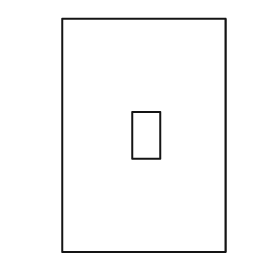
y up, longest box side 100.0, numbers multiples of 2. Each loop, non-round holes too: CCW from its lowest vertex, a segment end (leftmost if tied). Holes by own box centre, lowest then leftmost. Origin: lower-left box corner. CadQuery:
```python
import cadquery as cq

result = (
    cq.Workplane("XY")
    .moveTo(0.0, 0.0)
    .lineTo(70.0, 0.0)
    .lineTo(70.0, 100.0)
    .lineTo(0.0, 100.0)
    .close()
    .moveTo(30.0, 40.0)
    .lineTo(42.0, 40.0)
    .lineTo(42.0, 60.0)
    .lineTo(30.0, 60.0)
    .close()
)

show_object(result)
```